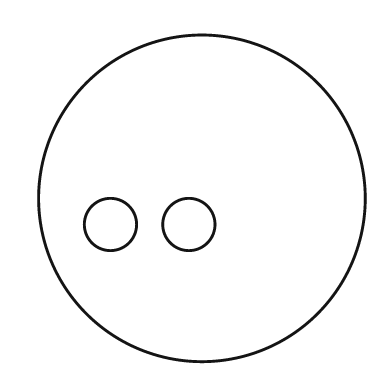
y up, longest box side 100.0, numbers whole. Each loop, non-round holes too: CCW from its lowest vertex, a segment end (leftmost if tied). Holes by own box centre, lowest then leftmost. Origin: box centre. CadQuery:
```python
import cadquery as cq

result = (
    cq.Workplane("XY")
    .moveTo(0.0, 0.0)
    .circle(50.0)
    .moveTo(-28.0, -8.0)
    .circle(8.0)
    .moveTo(-4.0, -8.0)
    .circle(8.0)
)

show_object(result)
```